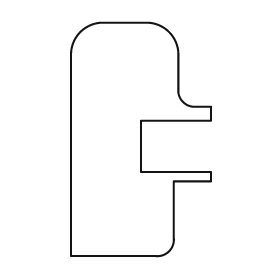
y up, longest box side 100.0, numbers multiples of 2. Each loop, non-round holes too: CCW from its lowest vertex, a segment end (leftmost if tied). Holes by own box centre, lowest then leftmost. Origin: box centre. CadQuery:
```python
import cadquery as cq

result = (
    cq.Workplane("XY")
    .moveTo(-30.0, -50.0)
    .lineTo(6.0, -50.0)
    .threePointArc((12.0, -48.0), (14.0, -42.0))
    .lineTo(14.0, -18.0)
    .lineTo(30.0, -18.0)
    .lineTo(30.0, -14.0)
    .lineTo(0.0, -14.0)
    .lineTo(0.0, 8.0)
    .lineTo(30.0, 8.0)
    .lineTo(30.0, 14.0)
    .lineTo(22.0, 14.0)
    .threePointArc((18.0, 16.0), (16.0, 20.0))
    .lineTo(16.0, 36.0)
    .threePointArc((12.0, 46.0), (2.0, 50.0))
    .lineTo(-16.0, 50.0)
    .threePointArc((-26.0, 46.0), (-30.0, 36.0))
    .close()
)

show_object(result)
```